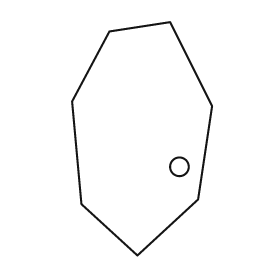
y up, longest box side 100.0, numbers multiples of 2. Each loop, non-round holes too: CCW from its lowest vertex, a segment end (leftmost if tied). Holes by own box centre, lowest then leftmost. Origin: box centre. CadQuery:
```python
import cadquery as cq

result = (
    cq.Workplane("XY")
    .moveTo(-2.0, -50.0)
    .lineTo(24.0, -26.0)
    .lineTo(30.0, 14.0)
    .lineTo(12.0, 50.0)
    .lineTo(-14.0, 46.0)
    .lineTo(-30.0, 16.0)
    .lineTo(-26.0, -28.0)
    .close()
    .moveTo(16.0, -12.0)
    .circle(4.0)
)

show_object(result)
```